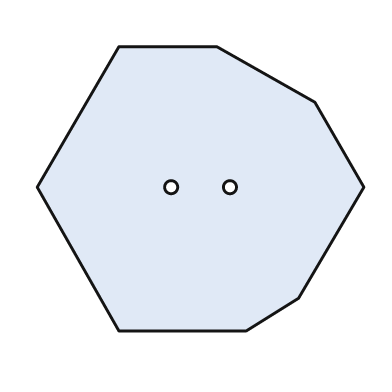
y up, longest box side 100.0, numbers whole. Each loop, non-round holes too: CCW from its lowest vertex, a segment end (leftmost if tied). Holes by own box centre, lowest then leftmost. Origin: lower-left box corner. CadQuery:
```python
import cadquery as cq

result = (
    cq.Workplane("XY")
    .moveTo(25.0, 0.0)
    .lineTo(64.0, 0.0)
    .lineTo(80.0, 10.0)
    .lineTo(100.0, 44.0)
    .lineTo(85.0, 70.0)
    .lineTo(55.0, 87.0)
    .lineTo(25.0, 87.0)
    .lineTo(0.0, 44.0)
    .close()
    .moveTo(41.0, 44.0)
    .circle(2.0)
    .moveTo(59.0, 44.0)
    .circle(2.0)
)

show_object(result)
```